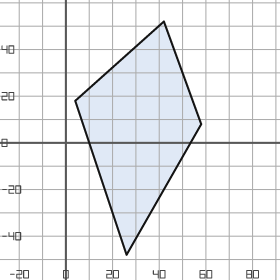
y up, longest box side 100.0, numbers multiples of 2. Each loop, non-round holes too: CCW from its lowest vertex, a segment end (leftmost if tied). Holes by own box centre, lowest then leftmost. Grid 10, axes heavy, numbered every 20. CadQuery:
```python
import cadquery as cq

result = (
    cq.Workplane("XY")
    .moveTo(26.0, -48.0)
    .lineTo(58.0, 8.0)
    .lineTo(42.0, 52.0)
    .lineTo(4.0, 18.0)
    .close()
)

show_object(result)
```